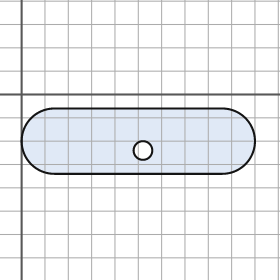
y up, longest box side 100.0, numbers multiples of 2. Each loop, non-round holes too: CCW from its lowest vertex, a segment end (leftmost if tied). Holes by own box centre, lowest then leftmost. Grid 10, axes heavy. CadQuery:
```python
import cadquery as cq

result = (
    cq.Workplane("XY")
    .moveTo(14.0, -34.0)
    .lineTo(86.0, -34.0)
    .threePointArc((100.0, -20.0), (86.0, -6.0))
    .lineTo(14.0, -6.0)
    .threePointArc((0.0, -20.0), (14.0, -34.0))
    .close()
    .moveTo(52.0, -24.0)
    .circle(4.0)
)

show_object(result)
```